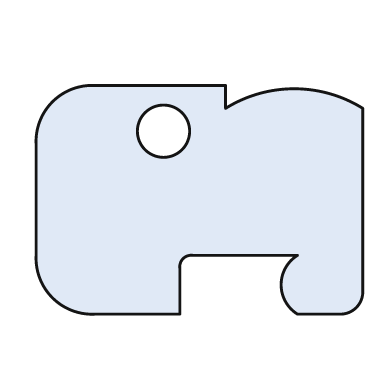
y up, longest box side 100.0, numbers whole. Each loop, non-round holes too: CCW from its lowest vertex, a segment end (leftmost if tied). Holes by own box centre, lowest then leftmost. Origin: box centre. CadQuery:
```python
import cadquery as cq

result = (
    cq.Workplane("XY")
    .moveTo(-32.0, -35.0)
    .lineTo(-6.0, -35.0)
    .lineTo(-6.0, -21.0)
    .threePointArc((-5.0, -18.0), (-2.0, -17.0))
    .lineTo(30.0, -17.0)
    .threePointArc((25.0, -26.0), (30.0, -35.0))
    .lineTo(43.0, -35.0)
    .threePointArc((48.0, -33.0), (50.0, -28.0))
    .lineTo(50.0, 28.0)
    .threePointArc((29.0, 34.0), (8.0, 28.0))
    .lineTo(8.0, 35.0)
    .lineTo(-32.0, 35.0)
    .threePointArc((-45.0, 30.0), (-50.0, 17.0))
    .lineTo(-50.0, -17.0)
    .threePointArc((-45.0, -30.0), (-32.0, -35.0))
    .close()
    .moveTo(-11.0, 21.0)
    .circle(8.0)
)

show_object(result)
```